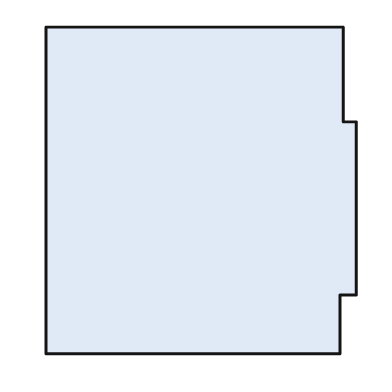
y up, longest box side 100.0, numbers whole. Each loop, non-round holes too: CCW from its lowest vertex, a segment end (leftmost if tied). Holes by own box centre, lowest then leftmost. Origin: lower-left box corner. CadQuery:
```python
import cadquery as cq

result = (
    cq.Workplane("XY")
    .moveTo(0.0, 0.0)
    .lineTo(90.0, 0.0)
    .lineTo(90.0, 18.0)
    .lineTo(95.0, 18.0)
    .lineTo(95.0, 71.0)
    .lineTo(91.0, 71.0)
    .lineTo(91.0, 100.0)
    .lineTo(0.0, 100.0)
    .close()
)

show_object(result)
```